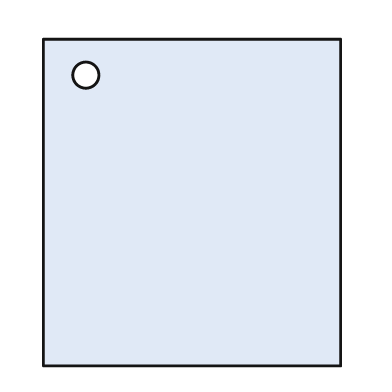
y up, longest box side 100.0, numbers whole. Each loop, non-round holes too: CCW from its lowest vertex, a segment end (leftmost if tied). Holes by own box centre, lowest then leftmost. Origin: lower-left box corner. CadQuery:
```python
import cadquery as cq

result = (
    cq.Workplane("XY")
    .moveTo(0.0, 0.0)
    .lineTo(91.0, 0.0)
    .lineTo(91.0, 100.0)
    .lineTo(0.0, 100.0)
    .close()
    .moveTo(13.0, 89.0)
    .circle(4.0)
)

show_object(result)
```